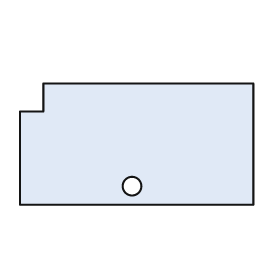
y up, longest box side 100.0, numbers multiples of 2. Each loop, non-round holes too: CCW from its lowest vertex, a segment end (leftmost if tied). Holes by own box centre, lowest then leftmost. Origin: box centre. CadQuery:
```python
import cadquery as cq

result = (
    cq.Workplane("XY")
    .moveTo(-50.0, -26.0)
    .lineTo(50.0, -26.0)
    .lineTo(50.0, 26.0)
    .lineTo(-40.0, 26.0)
    .lineTo(-40.0, 14.0)
    .lineTo(-50.0, 14.0)
    .close()
    .moveTo(-2.0, -18.0)
    .circle(4.0)
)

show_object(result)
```